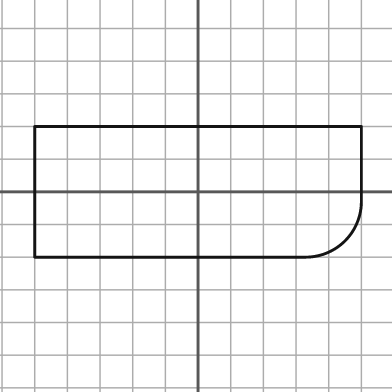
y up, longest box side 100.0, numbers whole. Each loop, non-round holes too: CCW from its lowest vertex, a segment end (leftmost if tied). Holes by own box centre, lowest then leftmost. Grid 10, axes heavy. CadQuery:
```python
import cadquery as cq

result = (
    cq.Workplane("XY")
    .moveTo(-50.0, -20.0)
    .lineTo(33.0, -20.0)
    .threePointArc((45.0, -15.0), (50.0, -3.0))
    .lineTo(50.0, 20.0)
    .lineTo(-50.0, 20.0)
    .close()
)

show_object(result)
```